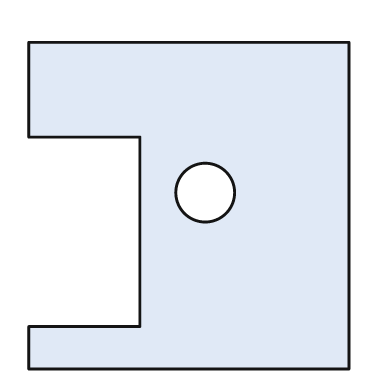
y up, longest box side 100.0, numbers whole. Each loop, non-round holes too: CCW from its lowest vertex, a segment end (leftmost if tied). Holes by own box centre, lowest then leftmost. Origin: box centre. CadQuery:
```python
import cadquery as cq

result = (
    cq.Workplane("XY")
    .moveTo(-49.0, -50.0)
    .lineTo(49.0, -50.0)
    .lineTo(49.0, 50.0)
    .lineTo(-49.0, 50.0)
    .lineTo(-49.0, 21.0)
    .lineTo(-15.0, 21.0)
    .lineTo(-15.0, -37.0)
    .lineTo(-49.0, -37.0)
    .close()
    .moveTo(5.0, 4.0)
    .circle(9.0)
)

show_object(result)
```